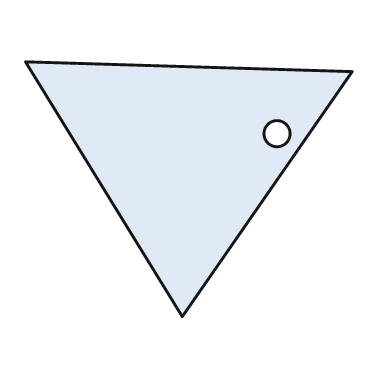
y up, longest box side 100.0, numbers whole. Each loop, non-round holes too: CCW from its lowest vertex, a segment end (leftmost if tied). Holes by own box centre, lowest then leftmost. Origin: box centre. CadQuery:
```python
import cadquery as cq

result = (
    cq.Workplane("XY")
    .moveTo(-2.0, -39.0)
    .lineTo(50.0, 36.0)
    .lineTo(-50.0, 39.0)
    .close()
    .moveTo(27.0, 17.0)
    .circle(4.0)
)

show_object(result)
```